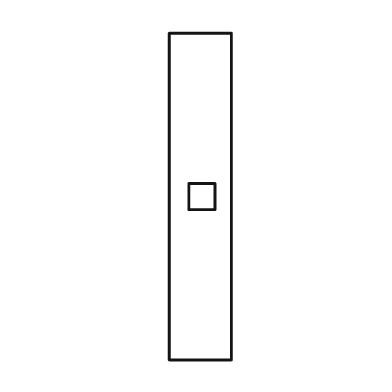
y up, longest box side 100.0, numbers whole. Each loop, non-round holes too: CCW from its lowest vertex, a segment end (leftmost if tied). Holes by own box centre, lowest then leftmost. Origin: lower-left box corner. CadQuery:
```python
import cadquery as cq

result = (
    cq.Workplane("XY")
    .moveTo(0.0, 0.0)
    .lineTo(19.0, 0.0)
    .lineTo(19.0, 100.0)
    .lineTo(0.0, 100.0)
    .close()
    .moveTo(6.0, 46.0)
    .lineTo(14.0, 46.0)
    .lineTo(14.0, 54.0)
    .lineTo(6.0, 54.0)
    .close()
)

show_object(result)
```